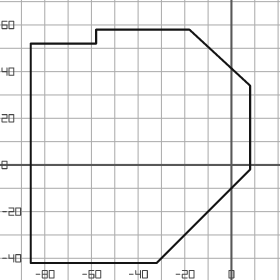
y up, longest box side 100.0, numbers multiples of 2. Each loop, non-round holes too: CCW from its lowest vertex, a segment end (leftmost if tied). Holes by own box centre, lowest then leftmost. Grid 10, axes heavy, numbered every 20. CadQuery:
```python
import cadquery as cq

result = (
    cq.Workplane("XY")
    .moveTo(-86.0, -42.0)
    .lineTo(-32.0, -42.0)
    .lineTo(8.0, -2.0)
    .lineTo(8.0, 34.0)
    .lineTo(-18.0, 58.0)
    .lineTo(-58.0, 58.0)
    .lineTo(-58.0, 52.0)
    .lineTo(-86.0, 52.0)
    .close()
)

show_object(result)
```